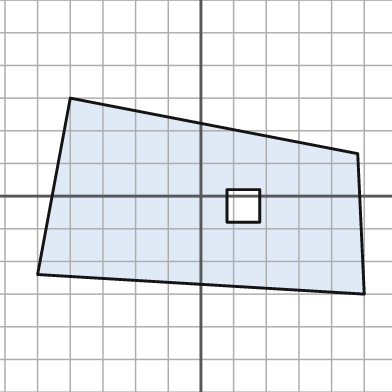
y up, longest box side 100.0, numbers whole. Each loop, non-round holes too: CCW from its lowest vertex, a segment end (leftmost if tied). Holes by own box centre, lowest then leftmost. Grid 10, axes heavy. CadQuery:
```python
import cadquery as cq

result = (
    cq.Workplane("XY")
    .moveTo(50.0, -30.0)
    .lineTo(48.0, 13.0)
    .lineTo(-40.0, 30.0)
    .lineTo(-50.0, -24.0)
    .close()
    .moveTo(8.0, -8.0)
    .lineTo(18.0, -8.0)
    .lineTo(18.0, 2.0)
    .lineTo(8.0, 2.0)
    .close()
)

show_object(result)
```